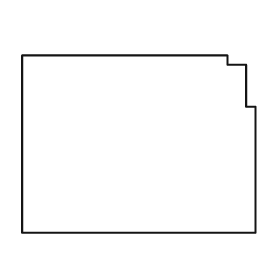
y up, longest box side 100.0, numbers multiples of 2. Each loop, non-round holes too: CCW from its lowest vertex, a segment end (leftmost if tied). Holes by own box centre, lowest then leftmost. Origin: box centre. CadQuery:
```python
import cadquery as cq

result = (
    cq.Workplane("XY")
    .moveTo(-50.0, -38.0)
    .lineTo(50.0, -38.0)
    .lineTo(50.0, 16.0)
    .lineTo(46.0, 16.0)
    .lineTo(46.0, 34.0)
    .lineTo(38.0, 34.0)
    .lineTo(38.0, 38.0)
    .lineTo(-50.0, 38.0)
    .close()
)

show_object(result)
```